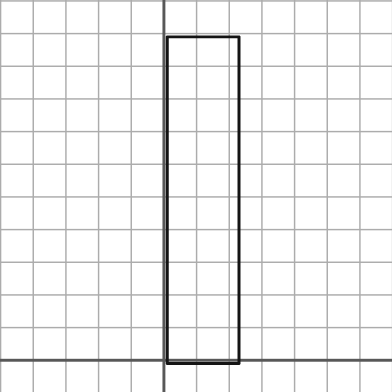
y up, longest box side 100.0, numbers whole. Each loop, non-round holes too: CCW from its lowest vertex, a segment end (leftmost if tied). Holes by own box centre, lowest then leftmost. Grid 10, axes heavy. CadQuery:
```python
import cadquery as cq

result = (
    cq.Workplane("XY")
    .moveTo(1.0, -1.0)
    .lineTo(23.0, -1.0)
    .lineTo(23.0, 99.0)
    .lineTo(1.0, 99.0)
    .close()
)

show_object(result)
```